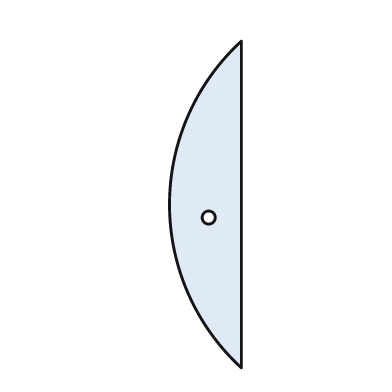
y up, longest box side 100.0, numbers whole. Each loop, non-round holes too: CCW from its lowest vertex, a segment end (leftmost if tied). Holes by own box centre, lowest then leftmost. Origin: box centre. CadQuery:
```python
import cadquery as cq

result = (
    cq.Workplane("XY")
    .moveTo(11.0, -50.0)
    .lineTo(11.0, 50.0)
    .threePointArc((-11.0, 0.0), (11.0, -50.0))
    .close()
    .moveTo(1.0, -4.0)
    .circle(2.0)
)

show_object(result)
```